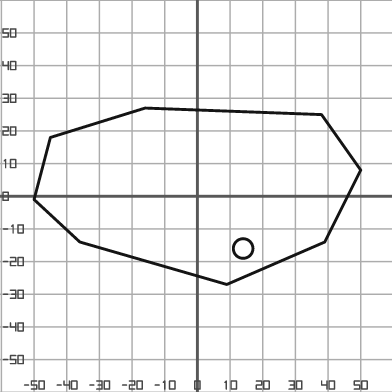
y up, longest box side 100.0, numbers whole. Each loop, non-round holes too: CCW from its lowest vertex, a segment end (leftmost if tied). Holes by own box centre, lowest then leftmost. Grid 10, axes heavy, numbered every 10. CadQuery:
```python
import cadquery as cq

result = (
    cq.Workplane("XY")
    .moveTo(9.0, -27.0)
    .lineTo(39.0, -14.0)
    .lineTo(50.0, 8.0)
    .lineTo(38.0, 25.0)
    .lineTo(-16.0, 27.0)
    .lineTo(-45.0, 18.0)
    .lineTo(-50.0, -1.0)
    .lineTo(-36.0, -14.0)
    .close()
    .moveTo(14.0, -16.0)
    .circle(3.0)
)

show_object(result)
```